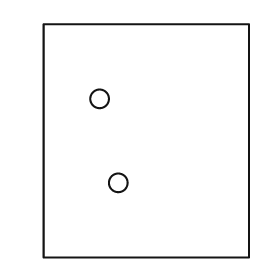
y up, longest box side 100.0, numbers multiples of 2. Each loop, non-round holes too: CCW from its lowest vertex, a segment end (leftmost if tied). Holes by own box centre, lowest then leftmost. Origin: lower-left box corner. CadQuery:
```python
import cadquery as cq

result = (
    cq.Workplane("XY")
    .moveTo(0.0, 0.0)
    .lineTo(88.0, 0.0)
    .lineTo(88.0, 100.0)
    .lineTo(0.0, 100.0)
    .close()
    .moveTo(32.0, 32.0)
    .circle(4.0)
    .moveTo(24.0, 68.0)
    .circle(4.0)
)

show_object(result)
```